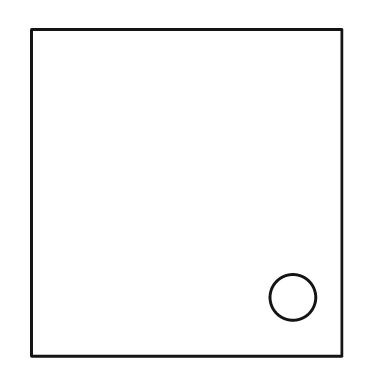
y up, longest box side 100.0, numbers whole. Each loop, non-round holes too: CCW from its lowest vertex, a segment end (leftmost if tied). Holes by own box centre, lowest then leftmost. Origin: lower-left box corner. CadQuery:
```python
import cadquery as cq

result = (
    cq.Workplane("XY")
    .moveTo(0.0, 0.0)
    .lineTo(95.0, 0.0)
    .lineTo(95.0, 100.0)
    .lineTo(0.0, 100.0)
    .close()
    .moveTo(80.0, 18.0)
    .circle(7.0)
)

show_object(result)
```